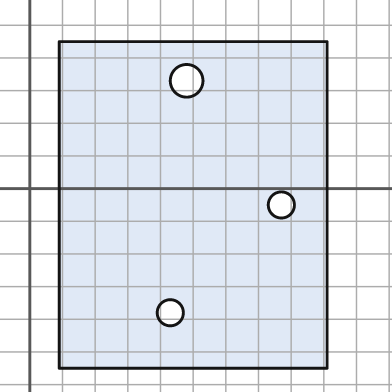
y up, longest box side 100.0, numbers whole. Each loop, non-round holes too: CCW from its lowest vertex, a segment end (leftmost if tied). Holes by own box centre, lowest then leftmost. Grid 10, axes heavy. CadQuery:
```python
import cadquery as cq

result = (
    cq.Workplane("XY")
    .moveTo(9.0, -55.0)
    .lineTo(91.0, -55.0)
    .lineTo(91.0, 45.0)
    .lineTo(9.0, 45.0)
    .close()
    .moveTo(43.0, -38.0)
    .circle(4.0)
    .moveTo(77.0, -5.0)
    .circle(4.0)
    .moveTo(48.0, 33.0)
    .circle(5.0)
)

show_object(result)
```